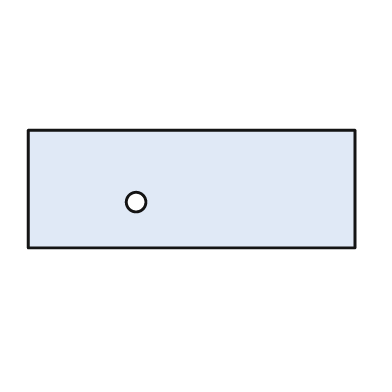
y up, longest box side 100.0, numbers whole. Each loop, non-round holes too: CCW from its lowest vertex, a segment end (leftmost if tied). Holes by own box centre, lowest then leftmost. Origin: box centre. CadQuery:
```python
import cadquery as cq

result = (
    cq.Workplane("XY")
    .moveTo(-50.0, -18.0)
    .lineTo(50.0, -18.0)
    .lineTo(50.0, 18.0)
    .lineTo(-50.0, 18.0)
    .close()
    .moveTo(-17.0, -4.0)
    .circle(3.0)
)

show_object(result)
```